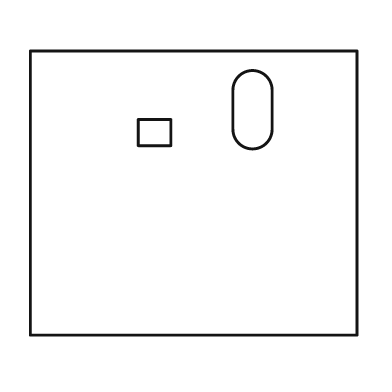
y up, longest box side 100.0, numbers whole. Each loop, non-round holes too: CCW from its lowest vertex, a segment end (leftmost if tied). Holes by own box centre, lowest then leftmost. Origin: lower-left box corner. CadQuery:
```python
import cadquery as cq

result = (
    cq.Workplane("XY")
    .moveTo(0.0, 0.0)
    .lineTo(100.0, 0.0)
    .lineTo(100.0, 87.0)
    .lineTo(0.0, 87.0)
    .close()
    .moveTo(33.0, 58.0)
    .lineTo(43.0, 58.0)
    .lineTo(43.0, 66.0)
    .lineTo(33.0, 66.0)
    .close()
    .moveTo(62.0, 63.0)
    .threePointArc((68.0, 57.0), (74.0, 63.0))
    .lineTo(74.0, 75.0)
    .threePointArc((68.0, 81.0), (62.0, 75.0))
    .close()
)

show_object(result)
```